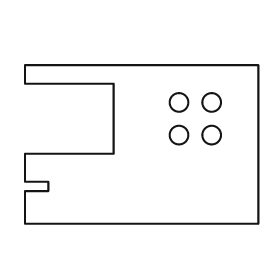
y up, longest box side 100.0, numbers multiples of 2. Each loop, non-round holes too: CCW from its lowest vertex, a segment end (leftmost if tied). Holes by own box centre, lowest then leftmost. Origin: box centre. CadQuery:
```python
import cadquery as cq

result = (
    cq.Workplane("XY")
    .moveTo(-50.0, -34.0)
    .lineTo(50.0, -34.0)
    .lineTo(50.0, 34.0)
    .lineTo(-50.0, 34.0)
    .lineTo(-50.0, 26.0)
    .lineTo(-12.0, 26.0)
    .lineTo(-12.0, -4.0)
    .lineTo(-50.0, -4.0)
    .lineTo(-50.0, -16.0)
    .lineTo(-40.0, -16.0)
    .lineTo(-40.0, -20.0)
    .lineTo(-50.0, -20.0)
    .close()
    .moveTo(16.0, 4.0)
    .circle(4.0)
    .moveTo(30.0, 4.0)
    .circle(4.0)
    .moveTo(16.0, 18.0)
    .circle(4.0)
    .moveTo(30.0, 18.0)
    .circle(4.0)
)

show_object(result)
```